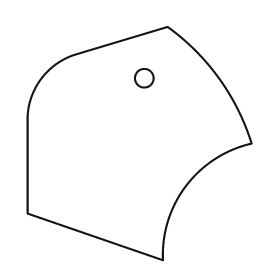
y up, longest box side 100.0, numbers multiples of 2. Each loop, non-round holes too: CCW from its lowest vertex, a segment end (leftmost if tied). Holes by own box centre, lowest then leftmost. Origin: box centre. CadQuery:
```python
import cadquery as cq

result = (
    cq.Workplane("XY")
    .moveTo(10.0, -50.0)
    .threePointArc((20.0, -18.0), (48.0, 0.0))
    .threePointArc((34.0, 28.0), (12.0, 50.0))
    .lineTo(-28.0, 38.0)
    .threePointArc((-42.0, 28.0), (-48.0, 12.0))
    .lineTo(-48.0, -30.0)
    .close()
    .moveTo(2.0, 28.0)
    .circle(4.0)
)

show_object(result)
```